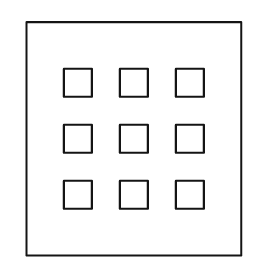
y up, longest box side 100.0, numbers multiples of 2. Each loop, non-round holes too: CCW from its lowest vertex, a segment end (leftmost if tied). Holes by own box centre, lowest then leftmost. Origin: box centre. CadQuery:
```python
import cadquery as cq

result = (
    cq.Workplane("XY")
    .moveTo(-46.0, -50.0)
    .lineTo(46.0, -50.0)
    .lineTo(46.0, 50.0)
    .lineTo(-46.0, 50.0)
    .close()
    .moveTo(-30.0, -30.0)
    .lineTo(-18.0, -30.0)
    .lineTo(-18.0, -18.0)
    .lineTo(-30.0, -18.0)
    .close()
    .moveTo(-6.0, -30.0)
    .lineTo(6.0, -30.0)
    .lineTo(6.0, -18.0)
    .lineTo(-6.0, -18.0)
    .close()
    .moveTo(18.0, -30.0)
    .lineTo(30.0, -30.0)
    .lineTo(30.0, -18.0)
    .lineTo(18.0, -18.0)
    .close()
    .moveTo(-30.0, -6.0)
    .lineTo(-18.0, -6.0)
    .lineTo(-18.0, 6.0)
    .lineTo(-30.0, 6.0)
    .close()
    .moveTo(-6.0, -6.0)
    .lineTo(6.0, -6.0)
    .lineTo(6.0, 6.0)
    .lineTo(-6.0, 6.0)
    .close()
    .moveTo(18.0, -6.0)
    .lineTo(30.0, -6.0)
    .lineTo(30.0, 6.0)
    .lineTo(18.0, 6.0)
    .close()
    .moveTo(-30.0, 18.0)
    .lineTo(-18.0, 18.0)
    .lineTo(-18.0, 30.0)
    .lineTo(-30.0, 30.0)
    .close()
    .moveTo(-6.0, 18.0)
    .lineTo(6.0, 18.0)
    .lineTo(6.0, 30.0)
    .lineTo(-6.0, 30.0)
    .close()
    .moveTo(18.0, 18.0)
    .lineTo(30.0, 18.0)
    .lineTo(30.0, 30.0)
    .lineTo(18.0, 30.0)
    .close()
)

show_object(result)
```